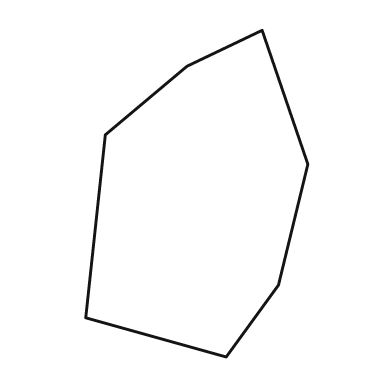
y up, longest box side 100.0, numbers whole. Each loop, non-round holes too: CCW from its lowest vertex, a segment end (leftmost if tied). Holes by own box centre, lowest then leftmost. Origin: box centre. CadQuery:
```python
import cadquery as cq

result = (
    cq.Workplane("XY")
    .moveTo(9.0, -50.0)
    .lineTo(25.0, -28.0)
    .lineTo(34.0, 9.0)
    .lineTo(20.0, 50.0)
    .lineTo(-3.0, 39.0)
    .lineTo(-28.0, 18.0)
    .lineTo(-34.0, -38.0)
    .close()
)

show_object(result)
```